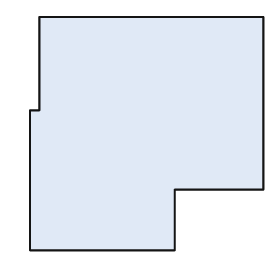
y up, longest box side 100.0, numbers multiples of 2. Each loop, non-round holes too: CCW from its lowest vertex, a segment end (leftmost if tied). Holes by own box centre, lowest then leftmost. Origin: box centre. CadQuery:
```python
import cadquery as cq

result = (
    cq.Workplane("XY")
    .moveTo(-50.0, -50.0)
    .lineTo(12.0, -50.0)
    .lineTo(12.0, -24.0)
    .lineTo(50.0, -24.0)
    .lineTo(50.0, 50.0)
    .lineTo(-46.0, 50.0)
    .lineTo(-46.0, 10.0)
    .lineTo(-50.0, 10.0)
    .close()
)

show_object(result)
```